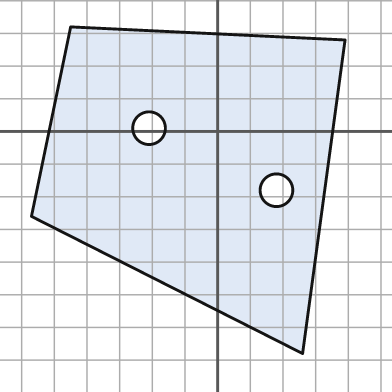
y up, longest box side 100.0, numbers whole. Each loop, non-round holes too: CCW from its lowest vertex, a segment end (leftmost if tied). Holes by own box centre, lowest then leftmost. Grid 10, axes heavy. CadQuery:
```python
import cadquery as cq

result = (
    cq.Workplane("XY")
    .moveTo(26.0, -68.0)
    .lineTo(39.0, 28.0)
    .lineTo(-45.0, 32.0)
    .lineTo(-57.0, -26.0)
    .close()
    .moveTo(18.0, -18.0)
    .circle(5.0)
    .moveTo(-21.0, 1.0)
    .circle(5.0)
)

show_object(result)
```